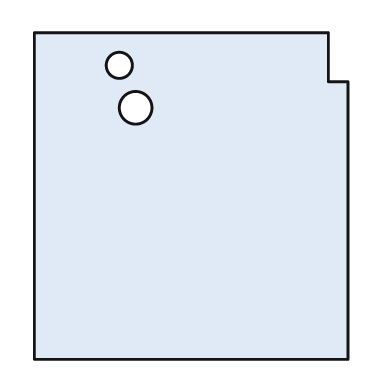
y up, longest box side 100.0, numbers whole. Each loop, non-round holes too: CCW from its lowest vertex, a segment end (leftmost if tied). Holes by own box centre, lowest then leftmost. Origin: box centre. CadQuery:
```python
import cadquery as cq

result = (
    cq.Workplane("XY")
    .moveTo(-48.0, -50.0)
    .lineTo(48.0, -50.0)
    .lineTo(48.0, 35.0)
    .lineTo(42.0, 35.0)
    .lineTo(42.0, 50.0)
    .lineTo(-48.0, 50.0)
    .close()
    .moveTo(-17.0, 27.0)
    .circle(5.0)
    .moveTo(-22.0, 40.0)
    .circle(4.0)
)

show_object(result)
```